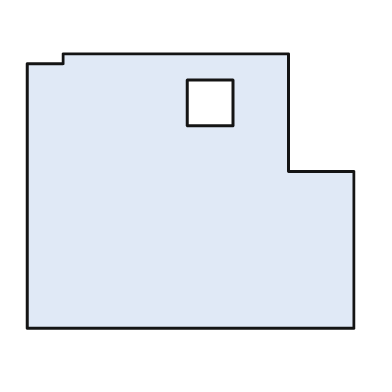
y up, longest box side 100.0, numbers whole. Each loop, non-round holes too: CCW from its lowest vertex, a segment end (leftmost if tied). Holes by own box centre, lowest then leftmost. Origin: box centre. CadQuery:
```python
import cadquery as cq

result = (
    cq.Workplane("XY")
    .moveTo(-50.0, -42.0)
    .lineTo(50.0, -42.0)
    .lineTo(50.0, 6.0)
    .lineTo(30.0, 6.0)
    .lineTo(30.0, 42.0)
    .lineTo(-39.0, 42.0)
    .lineTo(-39.0, 39.0)
    .lineTo(-50.0, 39.0)
    .close()
    .moveTo(-1.0, 20.0)
    .lineTo(13.0, 20.0)
    .lineTo(13.0, 34.0)
    .lineTo(-1.0, 34.0)
    .close()
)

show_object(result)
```